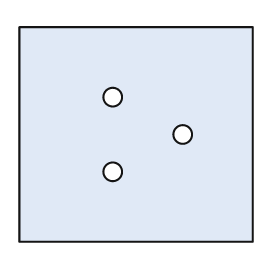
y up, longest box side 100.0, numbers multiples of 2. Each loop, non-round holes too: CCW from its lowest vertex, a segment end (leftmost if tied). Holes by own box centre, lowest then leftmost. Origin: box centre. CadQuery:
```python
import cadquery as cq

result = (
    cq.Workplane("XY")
    .moveTo(-50.0, -46.0)
    .lineTo(50.0, -46.0)
    .lineTo(50.0, 46.0)
    .lineTo(-50.0, 46.0)
    .close()
    .moveTo(-10.0, -16.0)
    .circle(4.0)
    .moveTo(20.0, 0.0)
    .circle(4.0)
    .moveTo(-10.0, 16.0)
    .circle(4.0)
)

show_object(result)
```